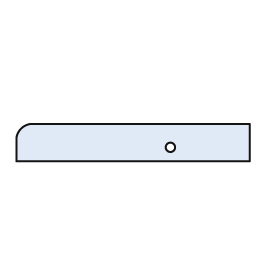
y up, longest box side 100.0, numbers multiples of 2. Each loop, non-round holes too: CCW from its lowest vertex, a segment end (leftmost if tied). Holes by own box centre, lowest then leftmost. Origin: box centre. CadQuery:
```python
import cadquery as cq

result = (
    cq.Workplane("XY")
    .moveTo(-50.0, -8.0)
    .lineTo(50.0, -8.0)
    .lineTo(50.0, 8.0)
    .lineTo(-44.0, 8.0)
    .threePointArc((-48.0, 6.0), (-50.0, 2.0))
    .close()
    .moveTo(16.0, -2.0)
    .circle(2.0)
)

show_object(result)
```